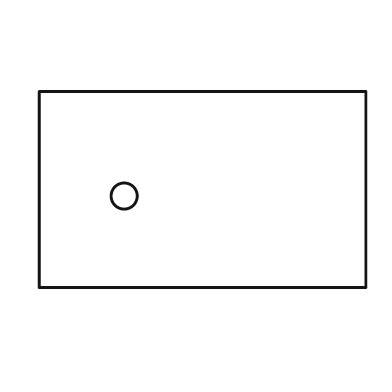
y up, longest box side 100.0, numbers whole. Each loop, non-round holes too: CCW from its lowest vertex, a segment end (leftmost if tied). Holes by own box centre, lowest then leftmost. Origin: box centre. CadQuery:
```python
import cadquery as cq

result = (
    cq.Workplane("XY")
    .moveTo(-50.0, -30.0)
    .lineTo(50.0, -30.0)
    .lineTo(50.0, 30.0)
    .lineTo(-50.0, 30.0)
    .close()
    .moveTo(-24.0, -2.0)
    .circle(4.0)
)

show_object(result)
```